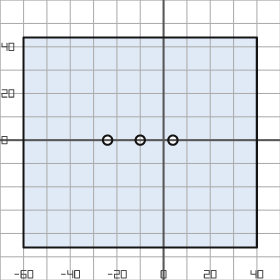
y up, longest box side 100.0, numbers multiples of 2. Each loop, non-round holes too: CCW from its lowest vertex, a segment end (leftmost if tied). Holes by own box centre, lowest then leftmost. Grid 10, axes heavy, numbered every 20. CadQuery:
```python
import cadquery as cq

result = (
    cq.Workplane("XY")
    .moveTo(-60.0, -46.0)
    .lineTo(40.0, -46.0)
    .lineTo(40.0, 44.0)
    .lineTo(-60.0, 44.0)
    .close()
    .moveTo(-24.0, 0.0)
    .circle(2.0)
    .moveTo(-10.0, 0.0)
    .circle(2.0)
    .moveTo(4.0, 0.0)
    .circle(2.0)
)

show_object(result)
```